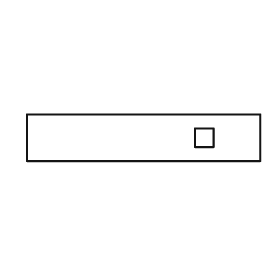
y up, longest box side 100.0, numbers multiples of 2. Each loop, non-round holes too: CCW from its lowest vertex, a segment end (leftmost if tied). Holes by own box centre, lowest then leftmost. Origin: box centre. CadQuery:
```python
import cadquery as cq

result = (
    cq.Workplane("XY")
    .moveTo(-50.0, -10.0)
    .lineTo(50.0, -10.0)
    .lineTo(50.0, 10.0)
    .lineTo(-50.0, 10.0)
    .close()
    .moveTo(22.0, -4.0)
    .lineTo(30.0, -4.0)
    .lineTo(30.0, 4.0)
    .lineTo(22.0, 4.0)
    .close()
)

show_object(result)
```